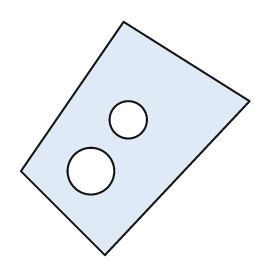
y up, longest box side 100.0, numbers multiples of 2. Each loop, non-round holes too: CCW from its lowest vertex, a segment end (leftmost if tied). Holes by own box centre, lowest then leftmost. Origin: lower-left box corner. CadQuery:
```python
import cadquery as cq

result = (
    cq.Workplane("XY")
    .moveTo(36.0, 0.0)
    .lineTo(98.0, 66.0)
    .lineTo(44.0, 100.0)
    .lineTo(0.0, 36.0)
    .close()
    .moveTo(30.0, 36.0)
    .circle(10.0)
    .moveTo(46.0, 58.0)
    .circle(8.0)
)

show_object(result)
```